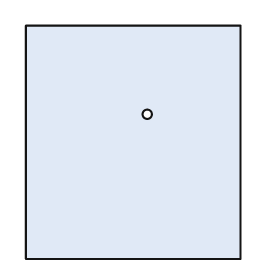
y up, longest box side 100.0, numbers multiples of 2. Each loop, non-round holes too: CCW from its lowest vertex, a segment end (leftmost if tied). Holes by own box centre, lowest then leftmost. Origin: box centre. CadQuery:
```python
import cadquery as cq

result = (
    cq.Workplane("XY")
    .moveTo(-46.0, -50.0)
    .lineTo(46.0, -50.0)
    .lineTo(46.0, 50.0)
    .lineTo(-46.0, 50.0)
    .close()
    .moveTo(6.0, 12.0)
    .circle(2.0)
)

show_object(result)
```